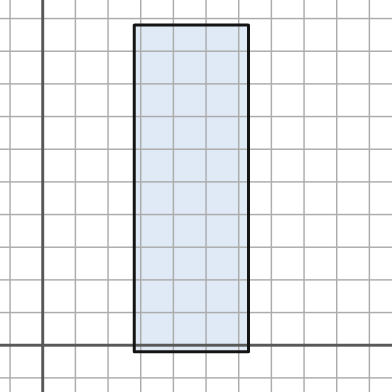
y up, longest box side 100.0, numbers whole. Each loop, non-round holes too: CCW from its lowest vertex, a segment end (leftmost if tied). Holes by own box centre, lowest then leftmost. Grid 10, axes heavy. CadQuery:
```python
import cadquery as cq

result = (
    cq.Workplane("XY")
    .moveTo(28.0, -2.0)
    .lineTo(63.0, -2.0)
    .lineTo(63.0, 98.0)
    .lineTo(28.0, 98.0)
    .close()
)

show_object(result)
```